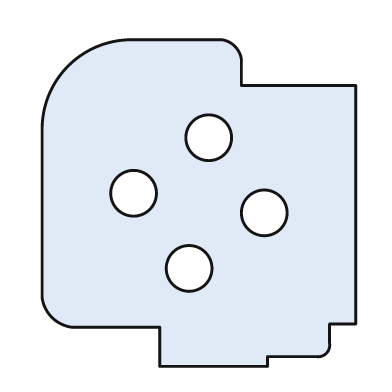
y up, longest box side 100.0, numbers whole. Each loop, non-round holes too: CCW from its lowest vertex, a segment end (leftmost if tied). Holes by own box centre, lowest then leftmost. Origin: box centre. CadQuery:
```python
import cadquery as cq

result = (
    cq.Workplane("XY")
    .moveTo(-12.0, -50.0)
    .lineTo(21.0, -50.0)
    .lineTo(21.0, -47.0)
    .lineTo(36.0, -47.0)
    .threePointArc((39.0, -46.0), (40.0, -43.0))
    .lineTo(40.0, -37.0)
    .lineTo(48.0, -37.0)
    .lineTo(48.0, 36.0)
    .lineTo(13.0, 36.0)
    .lineTo(13.0, 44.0)
    .threePointArc((11.0, 48.0), (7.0, 50.0))
    .lineTo(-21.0, 50.0)
    .threePointArc((-40.0, 42.0), (-48.0, 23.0))
    .lineTo(-48.0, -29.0)
    .threePointArc((-45.0, -35.0), (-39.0, -38.0))
    .lineTo(-12.0, -38.0)
    .close()
    .moveTo(-3.0, -20.0)
    .circle(7.0)
    .moveTo(20.0, -3.0)
    .circle(7.0)
    .moveTo(-20.0, 3.0)
    .circle(7.0)
    .moveTo(3.0, 20.0)
    .circle(7.0)
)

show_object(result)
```